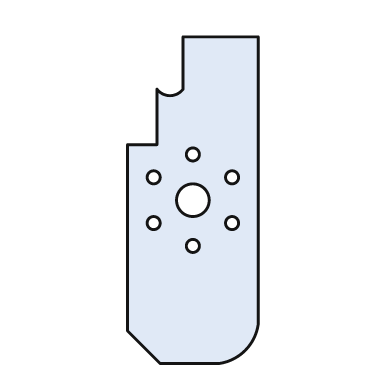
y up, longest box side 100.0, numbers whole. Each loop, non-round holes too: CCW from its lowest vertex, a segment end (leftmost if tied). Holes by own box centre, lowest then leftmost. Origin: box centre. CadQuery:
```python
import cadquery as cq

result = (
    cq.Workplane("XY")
    .moveTo(-10.0, -50.0)
    .lineTo(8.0, -50.0)
    .threePointArc((16.0, -46.0), (20.0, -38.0))
    .lineTo(20.0, 50.0)
    .lineTo(-3.0, 50.0)
    .lineTo(-3.0, 34.0)
    .threePointArc((-7.0, 32.0), (-11.0, 34.0))
    .lineTo(-11.0, 17.0)
    .lineTo(-20.0, 17.0)
    .lineTo(-20.0, -40.0)
    .close()
    .moveTo(0.0, -14.0)
    .circle(2.0)
    .moveTo(-12.0, -7.0)
    .circle(2.0)
    .moveTo(12.0, -7.0)
    .circle(2.0)
    .moveTo(0.0, 0.0)
    .circle(5.0)
    .moveTo(-12.0, 7.0)
    .circle(2.0)
    .moveTo(12.0, 7.0)
    .circle(2.0)
    .moveTo(0.0, 14.0)
    .circle(2.0)
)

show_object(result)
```